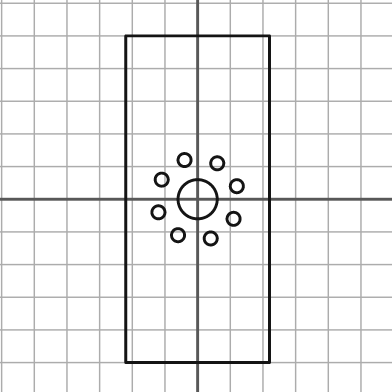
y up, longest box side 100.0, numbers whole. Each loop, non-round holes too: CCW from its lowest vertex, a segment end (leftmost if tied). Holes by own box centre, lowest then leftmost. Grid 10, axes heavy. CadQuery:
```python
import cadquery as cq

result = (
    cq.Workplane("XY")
    .moveTo(-22.0, -50.0)
    .lineTo(22.0, -50.0)
    .lineTo(22.0, 50.0)
    .lineTo(-22.0, 50.0)
    .close()
    .moveTo(4.0, -12.0)
    .circle(2.0)
    .moveTo(-6.0, -11.0)
    .circle(2.0)
    .moveTo(11.0, -6.0)
    .circle(2.0)
    .moveTo(-12.0, -4.0)
    .circle(2.0)
    .moveTo(0.0, 0.0)
    .circle(6.0)
    .moveTo(12.0, 4.0)
    .circle(2.0)
    .moveTo(-11.0, 6.0)
    .circle(2.0)
    .moveTo(6.0, 11.0)
    .circle(2.0)
    .moveTo(-4.0, 12.0)
    .circle(2.0)
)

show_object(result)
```